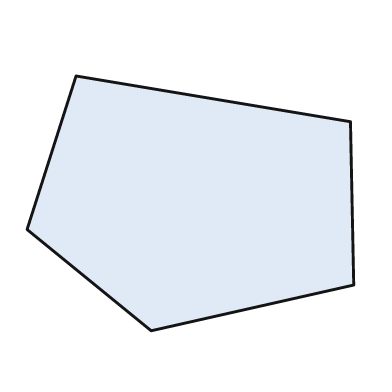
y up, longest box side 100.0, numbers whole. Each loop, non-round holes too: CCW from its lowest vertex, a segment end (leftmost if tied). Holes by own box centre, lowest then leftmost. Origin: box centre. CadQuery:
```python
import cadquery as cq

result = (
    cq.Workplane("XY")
    .moveTo(-12.0, -39.0)
    .lineTo(50.0, -25.0)
    .lineTo(49.0, 25.0)
    .lineTo(-35.0, 39.0)
    .lineTo(-50.0, -8.0)
    .close()
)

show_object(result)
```